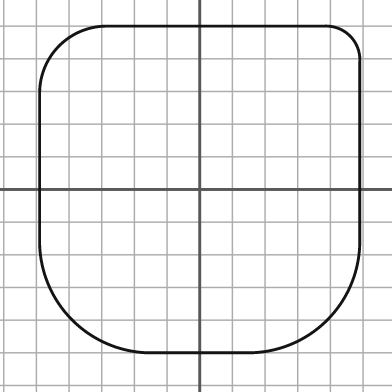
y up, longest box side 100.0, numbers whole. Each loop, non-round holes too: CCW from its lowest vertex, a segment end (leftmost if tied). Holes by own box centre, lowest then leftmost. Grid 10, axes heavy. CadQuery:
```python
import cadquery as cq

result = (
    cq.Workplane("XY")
    .moveTo(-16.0, -50.0)
    .lineTo(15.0, -50.0)
    .threePointArc((39.0, -40.0), (49.0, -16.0))
    .lineTo(49.0, 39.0)
    .threePointArc((46.0, 47.0), (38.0, 50.0))
    .lineTo(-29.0, 50.0)
    .threePointArc((-43.0, 44.0), (-49.0, 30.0))
    .lineTo(-49.0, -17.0)
    .threePointArc((-39.0, -40.0), (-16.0, -50.0))
    .close()
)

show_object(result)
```